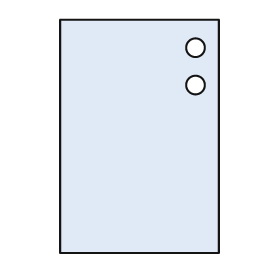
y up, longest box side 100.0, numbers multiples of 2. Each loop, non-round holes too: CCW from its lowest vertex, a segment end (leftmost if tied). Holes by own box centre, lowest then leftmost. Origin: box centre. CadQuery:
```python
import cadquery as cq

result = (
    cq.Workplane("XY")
    .moveTo(-34.0, -50.0)
    .lineTo(34.0, -50.0)
    .lineTo(34.0, 50.0)
    .lineTo(-34.0, 50.0)
    .close()
    .moveTo(24.0, 22.0)
    .circle(4.0)
    .moveTo(24.0, 38.0)
    .circle(4.0)
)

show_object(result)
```